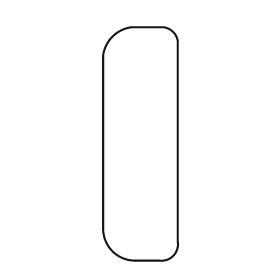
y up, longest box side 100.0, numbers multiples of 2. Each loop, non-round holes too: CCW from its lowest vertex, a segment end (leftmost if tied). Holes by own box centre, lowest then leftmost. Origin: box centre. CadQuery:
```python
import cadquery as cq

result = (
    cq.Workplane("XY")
    .moveTo(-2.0, -50.0)
    .lineTo(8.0, -50.0)
    .threePointArc((14.0, -48.0), (16.0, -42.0))
    .lineTo(16.0, 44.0)
    .threePointArc((14.0, 48.0), (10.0, 50.0))
    .lineTo(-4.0, 50.0)
    .threePointArc((-12.0, 46.0), (-16.0, 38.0))
    .lineTo(-16.0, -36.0)
    .threePointArc((-12.0, -46.0), (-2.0, -50.0))
    .close()
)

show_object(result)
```